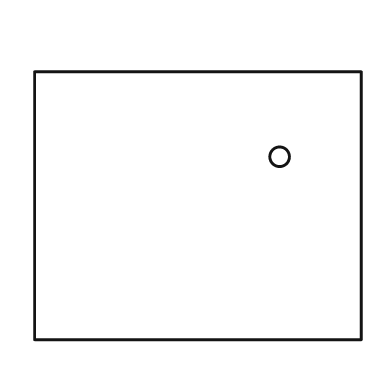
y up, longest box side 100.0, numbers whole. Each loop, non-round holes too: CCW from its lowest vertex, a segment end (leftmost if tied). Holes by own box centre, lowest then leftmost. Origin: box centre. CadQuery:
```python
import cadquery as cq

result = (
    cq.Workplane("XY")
    .moveTo(-50.0, -41.0)
    .lineTo(50.0, -41.0)
    .lineTo(50.0, 41.0)
    .lineTo(-50.0, 41.0)
    .close()
    .moveTo(25.0, 15.0)
    .circle(3.0)
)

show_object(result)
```